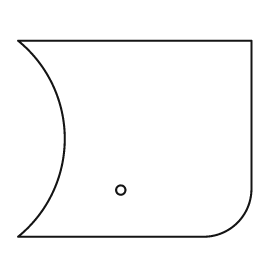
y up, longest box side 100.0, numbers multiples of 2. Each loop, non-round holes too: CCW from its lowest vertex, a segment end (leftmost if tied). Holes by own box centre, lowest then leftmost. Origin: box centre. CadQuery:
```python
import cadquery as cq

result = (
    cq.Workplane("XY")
    .moveTo(-50.0, -42.0)
    .lineTo(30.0, -42.0)
    .threePointArc((44.0, -36.0), (50.0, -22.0))
    .lineTo(50.0, 42.0)
    .lineTo(-50.0, 42.0)
    .threePointArc((-30.0, 0.0), (-50.0, -42.0))
    .close()
    .moveTo(-6.0, -22.0)
    .circle(2.0)
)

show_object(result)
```